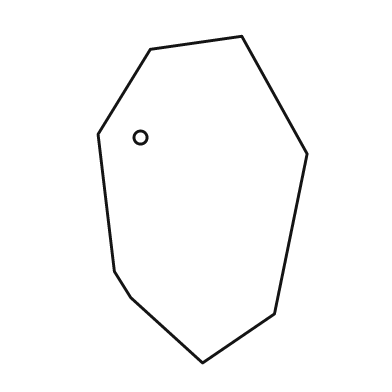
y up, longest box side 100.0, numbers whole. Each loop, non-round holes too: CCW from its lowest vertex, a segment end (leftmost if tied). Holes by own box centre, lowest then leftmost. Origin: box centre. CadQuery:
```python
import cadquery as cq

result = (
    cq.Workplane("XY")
    .moveTo(0.0, -50.0)
    .lineTo(22.0, -35.0)
    .lineTo(32.0, 14.0)
    .lineTo(12.0, 50.0)
    .lineTo(-16.0, 46.0)
    .lineTo(-32.0, 20.0)
    .lineTo(-27.0, -22.0)
    .lineTo(-22.0, -30.0)
    .close()
    .moveTo(-19.0, 19.0)
    .circle(2.0)
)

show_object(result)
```